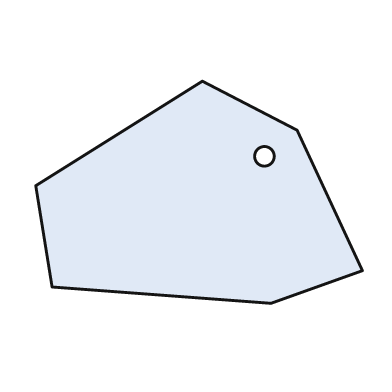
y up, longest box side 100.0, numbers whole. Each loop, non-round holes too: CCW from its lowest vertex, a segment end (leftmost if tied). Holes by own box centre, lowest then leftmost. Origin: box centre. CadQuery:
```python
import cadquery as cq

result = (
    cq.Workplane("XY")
    .moveTo(22.0, -34.0)
    .lineTo(50.0, -24.0)
    .lineTo(30.0, 19.0)
    .lineTo(1.0, 34.0)
    .lineTo(-50.0, 2.0)
    .lineTo(-45.0, -29.0)
    .close()
    .moveTo(20.0, 11.0)
    .circle(3.0)
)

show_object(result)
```